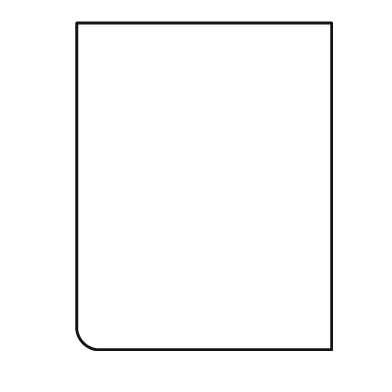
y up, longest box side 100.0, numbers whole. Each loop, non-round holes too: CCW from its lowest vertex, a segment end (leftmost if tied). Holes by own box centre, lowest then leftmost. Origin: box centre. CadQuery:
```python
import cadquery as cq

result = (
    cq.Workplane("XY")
    .moveTo(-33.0, -50.0)
    .lineTo(39.0, -50.0)
    .lineTo(39.0, 50.0)
    .lineTo(-39.0, 50.0)
    .lineTo(-39.0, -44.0)
    .threePointArc((-37.0, -48.0), (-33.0, -50.0))
    .close()
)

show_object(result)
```